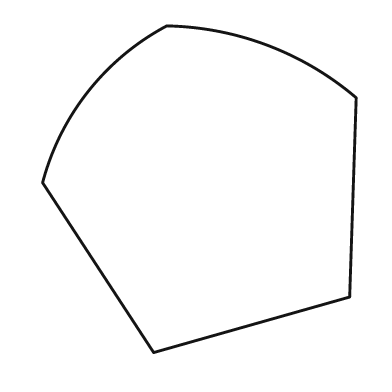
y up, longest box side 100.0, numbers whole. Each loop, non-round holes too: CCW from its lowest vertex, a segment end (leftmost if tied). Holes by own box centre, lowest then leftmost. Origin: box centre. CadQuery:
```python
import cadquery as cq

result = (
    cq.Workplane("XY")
    .moveTo(-14.0, -50.0)
    .lineTo(46.0, -33.0)
    .lineTo(48.0, 28.0)
    .threePointArc((21.0, 44.0), (-10.0, 50.0))
    .threePointArc((-34.0, 30.0), (-48.0, 2.0))
    .close()
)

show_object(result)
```